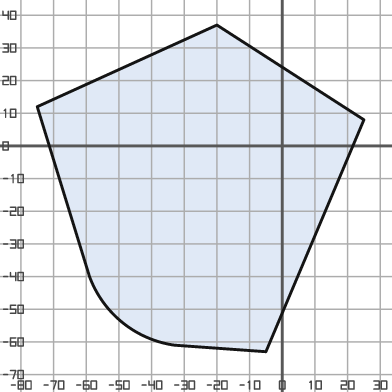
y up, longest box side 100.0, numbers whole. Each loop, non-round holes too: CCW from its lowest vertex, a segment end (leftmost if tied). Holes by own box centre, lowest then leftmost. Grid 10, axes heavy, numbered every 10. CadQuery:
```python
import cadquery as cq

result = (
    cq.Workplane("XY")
    .moveTo(-5.0, -63.0)
    .lineTo(25.0, 8.0)
    .lineTo(-20.0, 37.0)
    .lineTo(-75.0, 12.0)
    .lineTo(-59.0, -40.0)
    .threePointArc((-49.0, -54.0), (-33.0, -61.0))
    .close()
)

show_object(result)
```